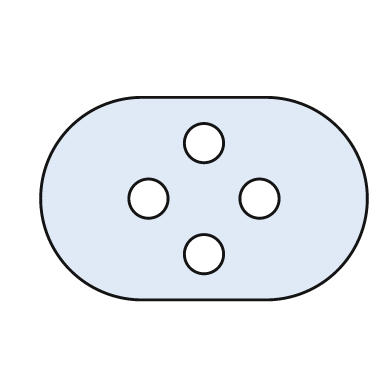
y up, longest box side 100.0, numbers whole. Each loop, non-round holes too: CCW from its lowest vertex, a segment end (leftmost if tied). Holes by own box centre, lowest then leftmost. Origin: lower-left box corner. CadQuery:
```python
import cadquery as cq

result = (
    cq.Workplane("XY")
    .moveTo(31.0, 0.0)
    .lineTo(69.0, 0.0)
    .threePointArc((100.0, 31.0), (69.0, 62.0))
    .lineTo(31.0, 62.0)
    .threePointArc((0.0, 31.0), (31.0, 0.0))
    .close()
    .moveTo(50.0, 14.0)
    .circle(6.0)
    .moveTo(33.0, 31.0)
    .circle(6.0)
    .moveTo(67.0, 31.0)
    .circle(6.0)
    .moveTo(50.0, 48.0)
    .circle(6.0)
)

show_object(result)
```